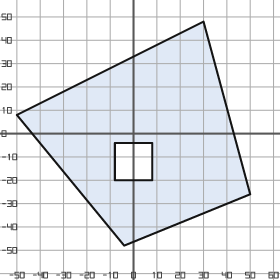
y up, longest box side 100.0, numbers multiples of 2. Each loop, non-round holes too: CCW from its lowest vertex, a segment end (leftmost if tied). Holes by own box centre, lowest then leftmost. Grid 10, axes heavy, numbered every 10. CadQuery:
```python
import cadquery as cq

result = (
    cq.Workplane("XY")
    .moveTo(-4.0, -48.0)
    .lineTo(50.0, -26.0)
    .lineTo(30.0, 48.0)
    .lineTo(-50.0, 8.0)
    .close()
    .moveTo(-8.0, -20.0)
    .lineTo(8.0, -20.0)
    .lineTo(8.0, -4.0)
    .lineTo(-8.0, -4.0)
    .close()
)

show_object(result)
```